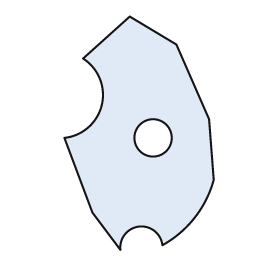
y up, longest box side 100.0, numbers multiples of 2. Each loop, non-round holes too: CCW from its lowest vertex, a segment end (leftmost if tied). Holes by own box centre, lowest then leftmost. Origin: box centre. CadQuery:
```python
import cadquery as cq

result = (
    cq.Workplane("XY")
    .moveTo(-8.0, -50.0)
    .threePointArc((0.0, -40.0), (10.0, -48.0))
    .threePointArc((24.0, -36.0), (32.0, -20.0))
    .lineTo(30.0, 6.0)
    .lineTo(16.0, 38.0)
    .lineTo(-4.0, 50.0)
    .lineTo(-24.0, 32.0)
    .threePointArc((-16.0, 12.0), (-32.0, -2.0))
    .lineTo(-20.0, -34.0)
    .close()
    .moveTo(6.0, -2.0)
    .circle(8.0)
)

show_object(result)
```